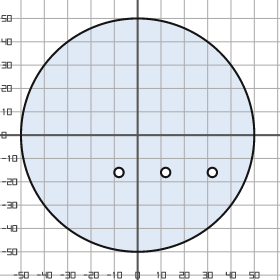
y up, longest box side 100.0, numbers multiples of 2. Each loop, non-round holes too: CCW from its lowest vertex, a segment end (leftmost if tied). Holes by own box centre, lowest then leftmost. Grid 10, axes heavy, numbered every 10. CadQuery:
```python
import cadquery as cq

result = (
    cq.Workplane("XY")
    .moveTo(0.0, 0.0)
    .circle(50.0)
    .moveTo(-8.0, -16.0)
    .circle(2.0)
    .moveTo(12.0, -16.0)
    .circle(2.0)
    .moveTo(32.0, -16.0)
    .circle(2.0)
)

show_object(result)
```